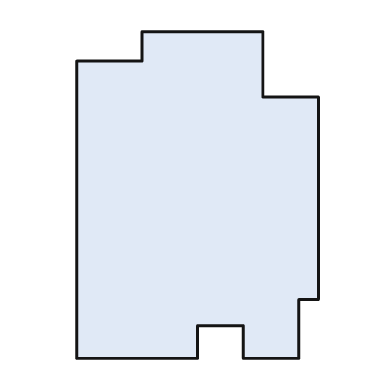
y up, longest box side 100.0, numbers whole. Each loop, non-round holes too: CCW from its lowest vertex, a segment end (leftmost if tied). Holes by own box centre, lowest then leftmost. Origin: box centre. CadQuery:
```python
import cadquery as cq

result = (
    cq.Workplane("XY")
    .moveTo(-37.0, -50.0)
    .lineTo(0.0, -50.0)
    .lineTo(0.0, -40.0)
    .lineTo(14.0, -40.0)
    .lineTo(14.0, -50.0)
    .lineTo(31.0, -50.0)
    .lineTo(31.0, -32.0)
    .lineTo(37.0, -32.0)
    .lineTo(37.0, 30.0)
    .lineTo(20.0, 30.0)
    .lineTo(20.0, 50.0)
    .lineTo(-17.0, 50.0)
    .lineTo(-17.0, 41.0)
    .lineTo(-37.0, 41.0)
    .close()
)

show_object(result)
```